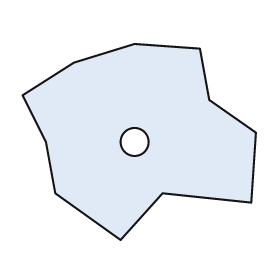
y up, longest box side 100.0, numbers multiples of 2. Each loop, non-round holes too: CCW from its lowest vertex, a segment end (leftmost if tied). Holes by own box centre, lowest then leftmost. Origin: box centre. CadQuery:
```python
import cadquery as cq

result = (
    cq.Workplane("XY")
    .moveTo(-8.0, -42.0)
    .lineTo(10.0, -22.0)
    .lineTo(48.0, -26.0)
    .lineTo(50.0, 4.0)
    .lineTo(30.0, 18.0)
    .lineTo(26.0, 40.0)
    .lineTo(-2.0, 42.0)
    .lineTo(-28.0, 34.0)
    .lineTo(-50.0, 20.0)
    .lineTo(-40.0, 0.0)
    .lineTo(-36.0, -22.0)
    .close()
    .moveTo(-2.0, 0.0)
    .circle(6.0)
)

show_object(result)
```